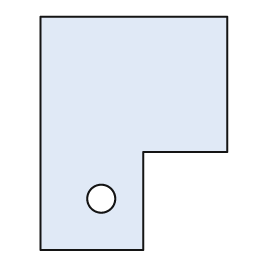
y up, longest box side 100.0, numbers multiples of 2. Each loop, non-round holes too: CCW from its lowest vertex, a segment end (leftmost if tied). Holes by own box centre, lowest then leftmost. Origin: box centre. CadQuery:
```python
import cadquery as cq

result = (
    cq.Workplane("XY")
    .moveTo(-40.0, -50.0)
    .lineTo(4.0, -50.0)
    .lineTo(4.0, -8.0)
    .lineTo(40.0, -8.0)
    .lineTo(40.0, 50.0)
    .lineTo(-40.0, 50.0)
    .close()
    .moveTo(-14.0, -28.0)
    .circle(6.0)
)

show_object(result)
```